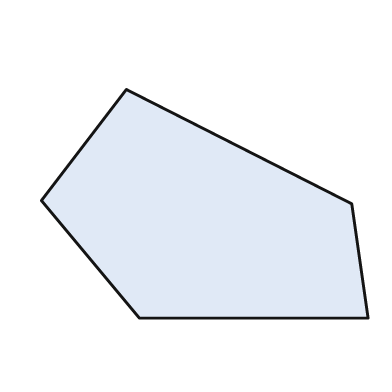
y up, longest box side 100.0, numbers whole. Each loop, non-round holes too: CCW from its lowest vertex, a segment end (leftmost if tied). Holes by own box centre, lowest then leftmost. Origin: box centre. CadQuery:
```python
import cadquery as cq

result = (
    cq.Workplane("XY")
    .moveTo(-20.0, -35.0)
    .lineTo(50.0, -35.0)
    .lineTo(45.0, 0.0)
    .lineTo(-24.0, 35.0)
    .lineTo(-50.0, 1.0)
    .close()
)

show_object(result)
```